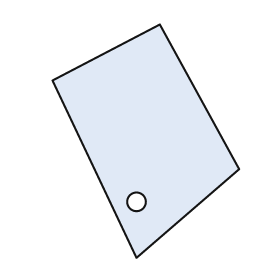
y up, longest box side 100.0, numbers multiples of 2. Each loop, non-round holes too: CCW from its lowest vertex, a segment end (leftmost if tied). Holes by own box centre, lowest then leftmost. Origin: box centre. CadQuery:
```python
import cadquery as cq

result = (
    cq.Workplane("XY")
    .moveTo(-4.0, -50.0)
    .lineTo(40.0, -12.0)
    .lineTo(6.0, 50.0)
    .lineTo(-40.0, 26.0)
    .close()
    .moveTo(-4.0, -26.0)
    .circle(4.0)
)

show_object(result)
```